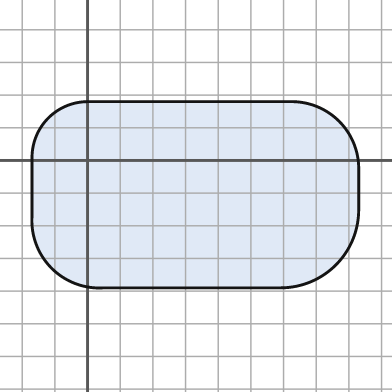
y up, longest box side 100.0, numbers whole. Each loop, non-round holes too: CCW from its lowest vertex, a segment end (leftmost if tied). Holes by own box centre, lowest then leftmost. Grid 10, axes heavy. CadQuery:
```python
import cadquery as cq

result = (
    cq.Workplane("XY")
    .moveTo(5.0, -39.0)
    .lineTo(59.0, -39.0)
    .threePointArc((76.0, -32.0), (83.0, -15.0))
    .lineTo(83.0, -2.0)
    .threePointArc((77.0, 12.0), (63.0, 18.0))
    .lineTo(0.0, 18.0)
    .threePointArc((-12.0, 13.0), (-17.0, 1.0))
    .lineTo(-17.0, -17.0)
    .threePointArc((-11.0, -33.0), (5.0, -39.0))
    .close()
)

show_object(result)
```